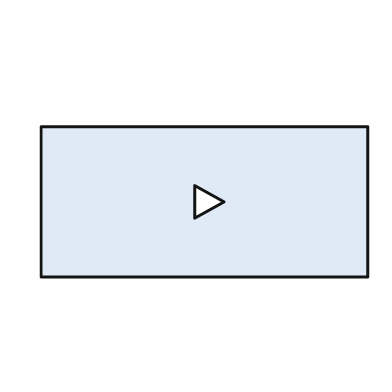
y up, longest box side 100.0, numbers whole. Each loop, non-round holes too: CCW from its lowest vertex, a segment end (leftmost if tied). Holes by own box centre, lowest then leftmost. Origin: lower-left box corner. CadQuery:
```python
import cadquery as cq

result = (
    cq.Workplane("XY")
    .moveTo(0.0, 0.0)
    .lineTo(100.0, 0.0)
    .lineTo(100.0, 46.0)
    .lineTo(0.0, 46.0)
    .close()
    .moveTo(47.0, 18.0)
    .lineTo(56.0, 23.0)
    .lineTo(47.0, 28.0)
    .close()
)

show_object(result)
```